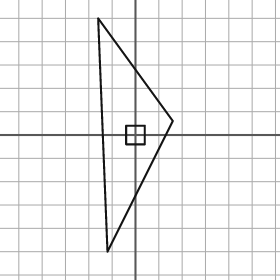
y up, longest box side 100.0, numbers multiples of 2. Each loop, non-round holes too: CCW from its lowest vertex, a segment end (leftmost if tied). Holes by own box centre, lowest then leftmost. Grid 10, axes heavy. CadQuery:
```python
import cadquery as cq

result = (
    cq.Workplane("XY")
    .moveTo(-12.0, -50.0)
    .lineTo(16.0, 6.0)
    .lineTo(-16.0, 50.0)
    .close()
    .moveTo(-4.0, -4.0)
    .lineTo(4.0, -4.0)
    .lineTo(4.0, 4.0)
    .lineTo(-4.0, 4.0)
    .close()
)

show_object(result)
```